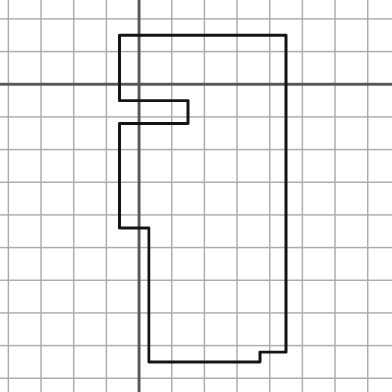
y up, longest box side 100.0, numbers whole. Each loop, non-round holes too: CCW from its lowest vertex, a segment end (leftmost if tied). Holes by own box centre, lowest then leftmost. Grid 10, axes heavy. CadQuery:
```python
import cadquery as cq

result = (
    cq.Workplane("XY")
    .moveTo(3.0, -85.0)
    .lineTo(37.0, -85.0)
    .lineTo(37.0, -82.0)
    .lineTo(45.0, -82.0)
    .lineTo(45.0, 15.0)
    .lineTo(-6.0, 15.0)
    .lineTo(-6.0, -5.0)
    .lineTo(15.0, -5.0)
    .lineTo(15.0, -12.0)
    .lineTo(-6.0, -12.0)
    .lineTo(-6.0, -44.0)
    .lineTo(3.0, -44.0)
    .close()
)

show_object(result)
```